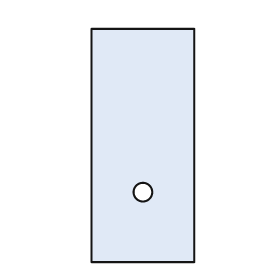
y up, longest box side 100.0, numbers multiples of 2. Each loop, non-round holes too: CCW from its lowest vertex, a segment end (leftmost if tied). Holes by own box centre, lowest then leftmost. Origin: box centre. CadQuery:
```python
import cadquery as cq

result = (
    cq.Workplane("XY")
    .moveTo(-22.0, -50.0)
    .lineTo(22.0, -50.0)
    .lineTo(22.0, 50.0)
    .lineTo(-22.0, 50.0)
    .close()
    .moveTo(0.0, -20.0)
    .circle(4.0)
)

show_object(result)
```